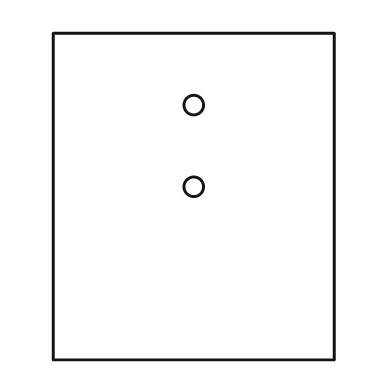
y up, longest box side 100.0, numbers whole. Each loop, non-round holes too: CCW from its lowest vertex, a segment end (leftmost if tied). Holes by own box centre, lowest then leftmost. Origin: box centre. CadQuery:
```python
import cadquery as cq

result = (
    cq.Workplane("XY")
    .moveTo(-43.0, -50.0)
    .lineTo(43.0, -50.0)
    .lineTo(43.0, 50.0)
    .lineTo(-43.0, 50.0)
    .close()
    .moveTo(0.0, 3.0)
    .circle(3.0)
    .moveTo(0.0, 28.0)
    .circle(3.0)
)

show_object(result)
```